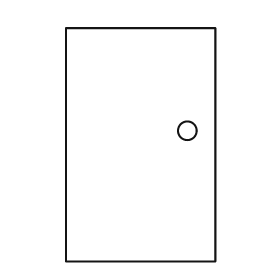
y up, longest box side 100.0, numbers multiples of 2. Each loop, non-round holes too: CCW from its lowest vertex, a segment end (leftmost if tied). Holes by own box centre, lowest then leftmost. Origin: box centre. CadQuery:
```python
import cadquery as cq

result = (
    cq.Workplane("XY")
    .moveTo(-32.0, -50.0)
    .lineTo(32.0, -50.0)
    .lineTo(32.0, 50.0)
    .lineTo(-32.0, 50.0)
    .close()
    .moveTo(20.0, 6.0)
    .circle(4.0)
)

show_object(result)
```